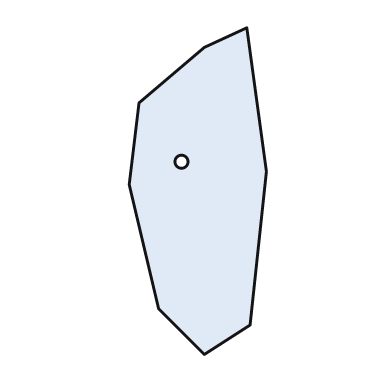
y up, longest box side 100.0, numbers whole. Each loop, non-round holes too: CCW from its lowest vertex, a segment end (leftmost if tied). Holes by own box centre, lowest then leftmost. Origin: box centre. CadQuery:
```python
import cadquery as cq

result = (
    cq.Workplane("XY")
    .moveTo(2.0, -50.0)
    .lineTo(16.0, -41.0)
    .lineTo(21.0, 6.0)
    .lineTo(15.0, 50.0)
    .lineTo(2.0, 44.0)
    .lineTo(-18.0, 27.0)
    .lineTo(-21.0, 2.0)
    .lineTo(-12.0, -36.0)
    .close()
    .moveTo(-5.0, 9.0)
    .circle(2.0)
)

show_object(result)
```